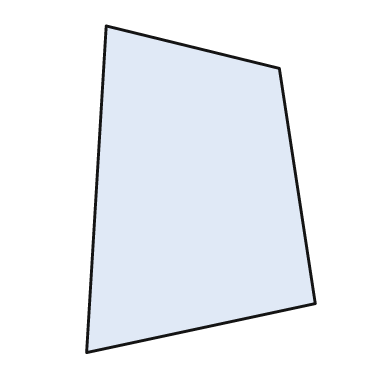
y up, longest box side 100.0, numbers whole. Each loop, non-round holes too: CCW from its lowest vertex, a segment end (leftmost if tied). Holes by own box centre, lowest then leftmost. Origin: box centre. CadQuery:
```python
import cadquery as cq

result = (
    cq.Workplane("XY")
    .moveTo(-35.0, -50.0)
    .lineTo(35.0, -35.0)
    .lineTo(24.0, 37.0)
    .lineTo(-29.0, 50.0)
    .close()
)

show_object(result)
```